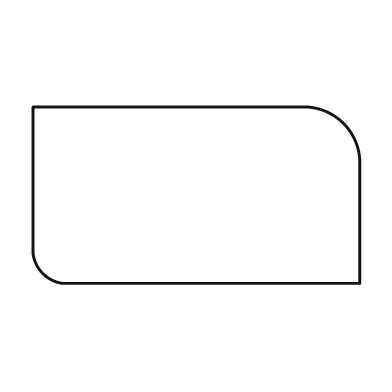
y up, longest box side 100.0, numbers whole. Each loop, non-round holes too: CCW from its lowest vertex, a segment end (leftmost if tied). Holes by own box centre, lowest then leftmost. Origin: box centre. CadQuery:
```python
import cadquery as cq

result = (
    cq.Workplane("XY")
    .moveTo(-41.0, -27.0)
    .lineTo(50.0, -27.0)
    .lineTo(50.0, 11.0)
    .threePointArc((45.0, 22.0), (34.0, 27.0))
    .lineTo(-50.0, 27.0)
    .lineTo(-50.0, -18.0)
    .threePointArc((-47.0, -24.0), (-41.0, -27.0))
    .close()
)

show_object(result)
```